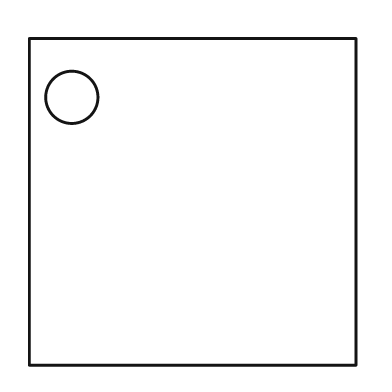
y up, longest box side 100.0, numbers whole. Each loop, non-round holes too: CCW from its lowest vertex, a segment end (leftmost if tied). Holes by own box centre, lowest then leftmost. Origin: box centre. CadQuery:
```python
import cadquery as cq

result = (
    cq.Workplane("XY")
    .moveTo(-50.0, -50.0)
    .lineTo(50.0, -50.0)
    .lineTo(50.0, 50.0)
    .lineTo(-50.0, 50.0)
    .close()
    .moveTo(-37.0, 32.0)
    .circle(8.0)
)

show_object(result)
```